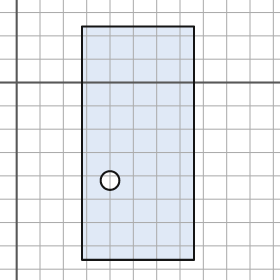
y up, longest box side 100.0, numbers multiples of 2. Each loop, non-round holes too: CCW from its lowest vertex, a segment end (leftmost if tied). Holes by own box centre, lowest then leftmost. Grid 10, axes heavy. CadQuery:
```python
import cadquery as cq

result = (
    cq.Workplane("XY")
    .moveTo(28.0, -76.0)
    .lineTo(76.0, -76.0)
    .lineTo(76.0, 24.0)
    .lineTo(28.0, 24.0)
    .close()
    .moveTo(40.0, -42.0)
    .circle(4.0)
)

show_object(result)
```